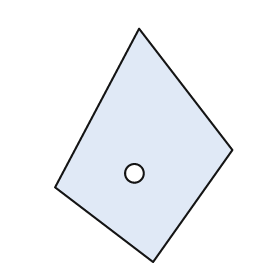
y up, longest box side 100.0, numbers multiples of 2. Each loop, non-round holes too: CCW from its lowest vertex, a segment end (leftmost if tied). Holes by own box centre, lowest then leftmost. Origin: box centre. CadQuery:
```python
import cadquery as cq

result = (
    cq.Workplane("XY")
    .moveTo(4.0, -50.0)
    .lineTo(38.0, -2.0)
    .lineTo(-2.0, 50.0)
    .lineTo(-38.0, -18.0)
    .close()
    .moveTo(-4.0, -12.0)
    .circle(4.0)
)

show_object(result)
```